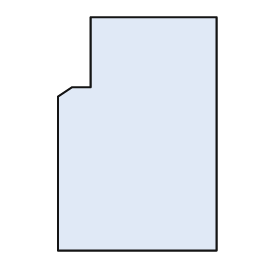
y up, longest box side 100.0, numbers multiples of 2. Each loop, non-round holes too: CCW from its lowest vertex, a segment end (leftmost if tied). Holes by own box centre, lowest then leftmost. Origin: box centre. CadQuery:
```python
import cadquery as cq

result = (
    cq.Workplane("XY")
    .moveTo(-34.0, -50.0)
    .lineTo(34.0, -50.0)
    .lineTo(34.0, 50.0)
    .lineTo(-20.0, 50.0)
    .lineTo(-20.0, 20.0)
    .lineTo(-28.0, 20.0)
    .lineTo(-34.0, 16.0)
    .close()
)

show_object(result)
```